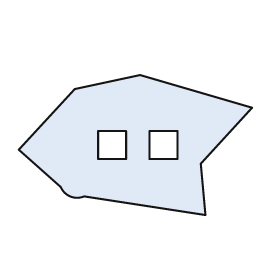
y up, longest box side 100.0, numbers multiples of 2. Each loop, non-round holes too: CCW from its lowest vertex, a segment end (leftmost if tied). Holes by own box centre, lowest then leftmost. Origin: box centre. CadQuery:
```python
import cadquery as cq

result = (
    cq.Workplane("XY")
    .moveTo(30.0, -30.0)
    .lineTo(28.0, -8.0)
    .lineTo(50.0, 16.0)
    .lineTo(2.0, 30.0)
    .lineTo(-26.0, 24.0)
    .lineTo(-50.0, -2.0)
    .lineTo(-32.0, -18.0)
    .threePointArc((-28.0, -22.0), (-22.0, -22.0))
    .close()
    .moveTo(-16.0, -6.0)
    .lineTo(-4.0, -6.0)
    .lineTo(-4.0, 6.0)
    .lineTo(-16.0, 6.0)
    .close()
    .moveTo(6.0, -6.0)
    .lineTo(18.0, -6.0)
    .lineTo(18.0, 6.0)
    .lineTo(6.0, 6.0)
    .close()
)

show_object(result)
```